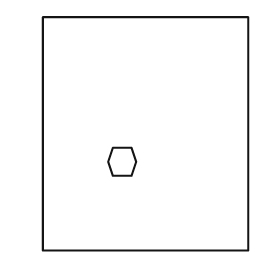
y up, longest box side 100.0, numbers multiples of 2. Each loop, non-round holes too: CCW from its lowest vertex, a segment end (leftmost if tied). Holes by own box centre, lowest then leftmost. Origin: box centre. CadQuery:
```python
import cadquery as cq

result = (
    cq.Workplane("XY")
    .moveTo(-44.0, -50.0)
    .lineTo(44.0, -50.0)
    .lineTo(44.0, 50.0)
    .lineTo(-44.0, 50.0)
    .close()
    .moveTo(-14.0, -18.0)
    .lineTo(-6.0, -18.0)
    .lineTo(-4.0, -12.0)
    .lineTo(-6.0, -6.0)
    .lineTo(-14.0, -6.0)
    .lineTo(-16.0, -12.0)
    .close()
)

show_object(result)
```